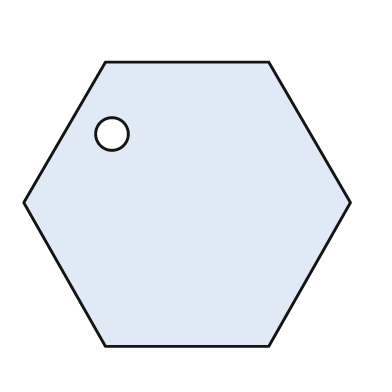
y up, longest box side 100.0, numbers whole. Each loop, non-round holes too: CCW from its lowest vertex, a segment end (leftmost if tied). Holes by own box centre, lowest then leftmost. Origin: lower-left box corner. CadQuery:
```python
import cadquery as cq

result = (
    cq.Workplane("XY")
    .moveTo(25.0, 0.0)
    .lineTo(75.0, 0.0)
    .lineTo(100.0, 44.0)
    .lineTo(75.0, 87.0)
    .lineTo(25.0, 87.0)
    .lineTo(0.0, 44.0)
    .close()
    .moveTo(27.0, 65.0)
    .circle(5.0)
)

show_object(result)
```